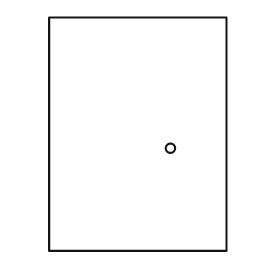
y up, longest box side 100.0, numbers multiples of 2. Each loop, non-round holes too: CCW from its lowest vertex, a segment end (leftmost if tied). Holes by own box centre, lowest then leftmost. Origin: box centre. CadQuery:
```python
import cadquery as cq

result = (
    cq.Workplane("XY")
    .moveTo(-38.0, -50.0)
    .lineTo(38.0, -50.0)
    .lineTo(38.0, 50.0)
    .lineTo(-38.0, 50.0)
    .close()
    .moveTo(14.0, -6.0)
    .circle(2.0)
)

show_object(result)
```